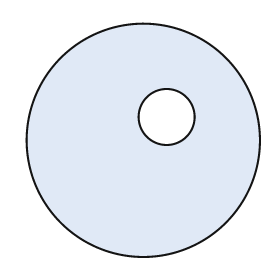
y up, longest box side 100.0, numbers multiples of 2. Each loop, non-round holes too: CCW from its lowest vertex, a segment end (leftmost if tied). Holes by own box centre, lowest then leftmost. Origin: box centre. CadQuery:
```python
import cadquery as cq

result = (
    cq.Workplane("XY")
    .moveTo(0.0, 0.0)
    .circle(50.0)
    .moveTo(10.0, 10.0)
    .circle(12.0)
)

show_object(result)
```